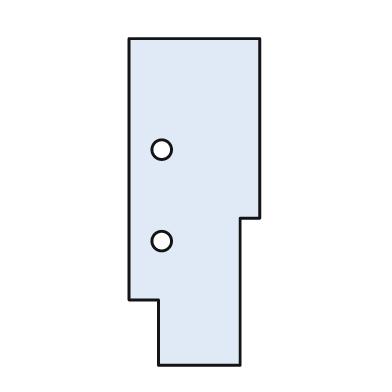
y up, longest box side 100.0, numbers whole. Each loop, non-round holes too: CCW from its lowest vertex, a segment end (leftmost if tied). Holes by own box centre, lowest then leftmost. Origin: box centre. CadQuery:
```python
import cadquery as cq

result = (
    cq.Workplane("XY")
    .moveTo(-11.0, -50.0)
    .lineTo(14.0, -50.0)
    .lineTo(14.0, -5.0)
    .lineTo(20.0, -5.0)
    .lineTo(20.0, 50.0)
    .lineTo(-20.0, 50.0)
    .lineTo(-20.0, -30.0)
    .lineTo(-11.0, -30.0)
    .close()
    .moveTo(-10.0, -12.0)
    .circle(3.0)
    .moveTo(-10.0, 16.0)
    .circle(3.0)
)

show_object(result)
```